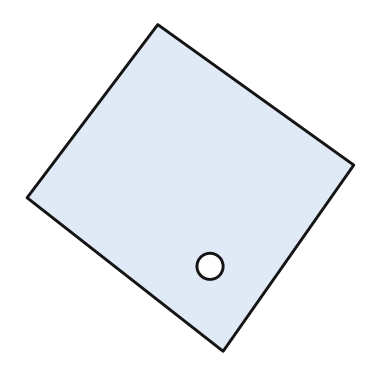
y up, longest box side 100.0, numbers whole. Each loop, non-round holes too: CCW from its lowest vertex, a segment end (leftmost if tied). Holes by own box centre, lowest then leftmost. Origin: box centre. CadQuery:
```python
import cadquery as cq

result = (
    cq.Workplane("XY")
    .moveTo(10.0, -50.0)
    .lineTo(50.0, 7.0)
    .lineTo(-10.0, 50.0)
    .lineTo(-50.0, -3.0)
    .close()
    .moveTo(6.0, -24.0)
    .circle(4.0)
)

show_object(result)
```